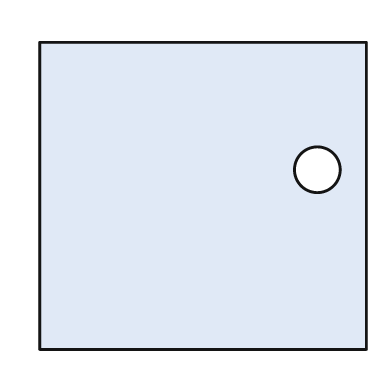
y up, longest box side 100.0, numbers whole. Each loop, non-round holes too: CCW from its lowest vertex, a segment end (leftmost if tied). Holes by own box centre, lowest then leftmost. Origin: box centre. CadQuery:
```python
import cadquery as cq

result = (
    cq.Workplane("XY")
    .moveTo(-50.0, -47.0)
    .lineTo(50.0, -47.0)
    .lineTo(50.0, 47.0)
    .lineTo(-50.0, 47.0)
    .close()
    .moveTo(35.0, 8.0)
    .circle(7.0)
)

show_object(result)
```